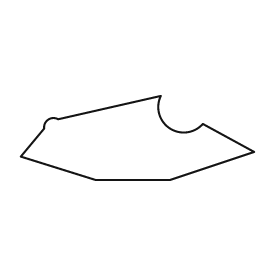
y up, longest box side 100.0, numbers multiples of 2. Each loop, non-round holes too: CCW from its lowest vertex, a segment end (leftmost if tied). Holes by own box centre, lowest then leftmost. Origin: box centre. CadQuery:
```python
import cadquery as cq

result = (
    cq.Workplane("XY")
    .moveTo(-18.0, -18.0)
    .lineTo(14.0, -18.0)
    .lineTo(50.0, -6.0)
    .lineTo(28.0, 6.0)
    .threePointArc((14.0, 4.0), (10.0, 18.0))
    .lineTo(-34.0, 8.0)
    .threePointArc((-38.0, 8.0), (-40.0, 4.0))
    .lineTo(-50.0, -8.0)
    .close()
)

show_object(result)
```